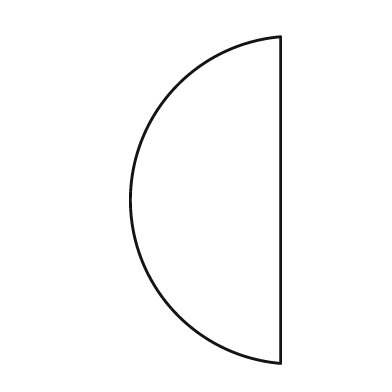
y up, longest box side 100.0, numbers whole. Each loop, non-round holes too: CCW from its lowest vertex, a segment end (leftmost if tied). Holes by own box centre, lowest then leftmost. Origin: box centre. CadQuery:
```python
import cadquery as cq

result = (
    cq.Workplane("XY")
    .moveTo(23.0, -50.0)
    .lineTo(23.0, 50.0)
    .threePointArc((-23.0, 0.0), (23.0, -50.0))
    .close()
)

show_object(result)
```